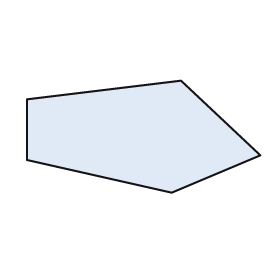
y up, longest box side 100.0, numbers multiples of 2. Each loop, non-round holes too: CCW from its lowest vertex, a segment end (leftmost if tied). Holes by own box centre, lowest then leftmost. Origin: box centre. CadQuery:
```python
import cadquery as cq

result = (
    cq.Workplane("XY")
    .moveTo(12.0, -24.0)
    .lineTo(50.0, -8.0)
    .lineTo(16.0, 24.0)
    .lineTo(-50.0, 16.0)
    .lineTo(-50.0, -10.0)
    .close()
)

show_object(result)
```